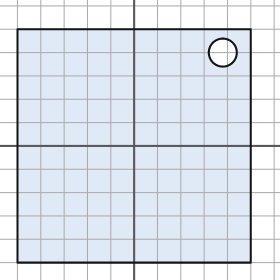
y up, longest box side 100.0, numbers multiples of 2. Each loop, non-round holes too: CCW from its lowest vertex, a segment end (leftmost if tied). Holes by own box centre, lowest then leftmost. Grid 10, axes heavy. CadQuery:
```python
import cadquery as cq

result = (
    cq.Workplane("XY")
    .moveTo(-50.0, -50.0)
    .lineTo(50.0, -50.0)
    .lineTo(50.0, 50.0)
    .lineTo(-50.0, 50.0)
    .close()
    .moveTo(38.0, 40.0)
    .circle(6.0)
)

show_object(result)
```